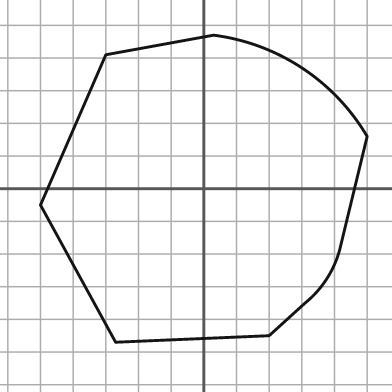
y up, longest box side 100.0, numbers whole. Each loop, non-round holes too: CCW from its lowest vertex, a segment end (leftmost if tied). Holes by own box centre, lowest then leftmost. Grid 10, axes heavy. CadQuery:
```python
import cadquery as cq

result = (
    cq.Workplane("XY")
    .moveTo(-27.0, -47.0)
    .lineTo(20.0, -45.0)
    .lineTo(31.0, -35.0)
    .threePointArc((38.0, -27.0), (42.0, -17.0))
    .lineTo(50.0, 16.0)
    .threePointArc((30.0, 37.0), (3.0, 47.0))
    .lineTo(-30.0, 41.0)
    .lineTo(-50.0, -5.0)
    .close()
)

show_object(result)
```